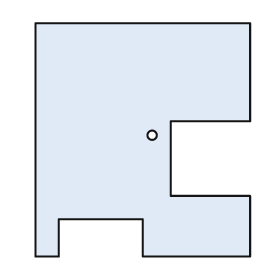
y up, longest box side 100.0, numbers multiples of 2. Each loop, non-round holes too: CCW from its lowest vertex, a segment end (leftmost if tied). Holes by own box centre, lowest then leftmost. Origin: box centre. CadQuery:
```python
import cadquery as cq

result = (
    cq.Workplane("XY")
    .moveTo(-46.0, -50.0)
    .lineTo(-36.0, -50.0)
    .lineTo(-36.0, -34.0)
    .lineTo(0.0, -34.0)
    .lineTo(0.0, -50.0)
    .lineTo(46.0, -50.0)
    .lineTo(46.0, -24.0)
    .lineTo(12.0, -24.0)
    .lineTo(12.0, 8.0)
    .lineTo(46.0, 8.0)
    .lineTo(46.0, 50.0)
    .lineTo(-46.0, 50.0)
    .close()
    .moveTo(4.0, 2.0)
    .circle(2.0)
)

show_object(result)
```